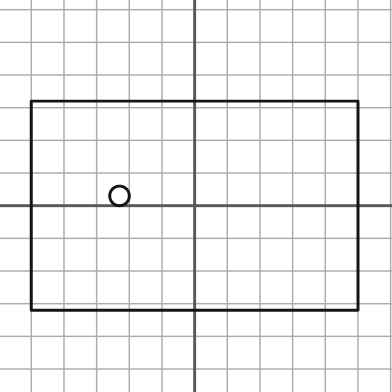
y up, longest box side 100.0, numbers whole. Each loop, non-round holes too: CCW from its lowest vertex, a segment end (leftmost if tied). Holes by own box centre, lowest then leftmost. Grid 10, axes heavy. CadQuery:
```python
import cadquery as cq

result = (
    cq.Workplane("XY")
    .moveTo(-50.0, -32.0)
    .lineTo(50.0, -32.0)
    .lineTo(50.0, 32.0)
    .lineTo(-50.0, 32.0)
    .close()
    .moveTo(-23.0, 3.0)
    .circle(3.0)
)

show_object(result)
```